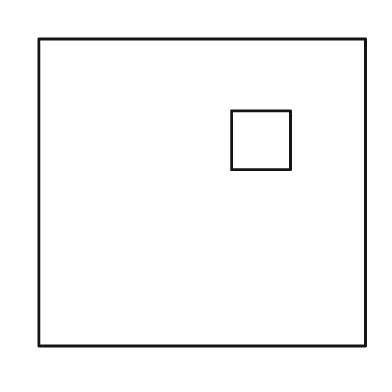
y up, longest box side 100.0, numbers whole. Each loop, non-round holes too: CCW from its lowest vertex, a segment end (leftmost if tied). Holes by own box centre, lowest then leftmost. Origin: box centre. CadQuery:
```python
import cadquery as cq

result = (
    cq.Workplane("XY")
    .moveTo(-50.0, -47.0)
    .lineTo(50.0, -47.0)
    .lineTo(50.0, 47.0)
    .lineTo(-50.0, 47.0)
    .close()
    .moveTo(9.0, 7.0)
    .lineTo(27.0, 7.0)
    .lineTo(27.0, 25.0)
    .lineTo(9.0, 25.0)
    .close()
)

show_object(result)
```